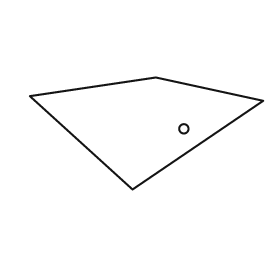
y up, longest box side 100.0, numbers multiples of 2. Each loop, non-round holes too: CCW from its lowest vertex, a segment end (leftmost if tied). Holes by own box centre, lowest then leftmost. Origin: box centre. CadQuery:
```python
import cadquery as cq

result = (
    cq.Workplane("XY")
    .moveTo(-6.0, -24.0)
    .lineTo(50.0, 14.0)
    .lineTo(4.0, 24.0)
    .lineTo(-50.0, 16.0)
    .close()
    .moveTo(16.0, 2.0)
    .circle(2.0)
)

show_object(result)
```